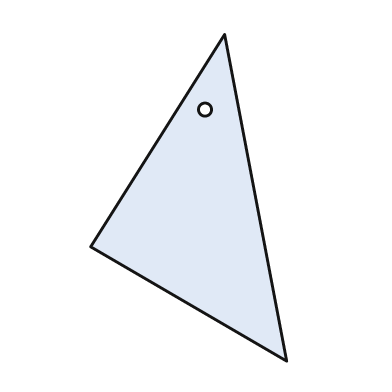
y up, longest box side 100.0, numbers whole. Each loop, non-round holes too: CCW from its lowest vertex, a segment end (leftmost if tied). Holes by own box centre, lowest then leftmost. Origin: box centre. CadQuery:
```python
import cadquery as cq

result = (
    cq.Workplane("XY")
    .moveTo(30.0, -50.0)
    .lineTo(11.0, 50.0)
    .lineTo(-30.0, -15.0)
    .close()
    .moveTo(5.0, 27.0)
    .circle(2.0)
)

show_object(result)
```